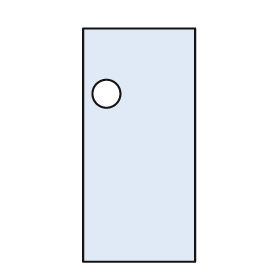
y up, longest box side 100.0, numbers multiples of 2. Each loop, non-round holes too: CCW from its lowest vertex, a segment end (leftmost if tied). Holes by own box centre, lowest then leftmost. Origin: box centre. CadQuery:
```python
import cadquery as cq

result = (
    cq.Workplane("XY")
    .moveTo(-24.0, -50.0)
    .lineTo(24.0, -50.0)
    .lineTo(24.0, 50.0)
    .lineTo(-24.0, 50.0)
    .close()
    .moveTo(-14.0, 22.0)
    .circle(6.0)
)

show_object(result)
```